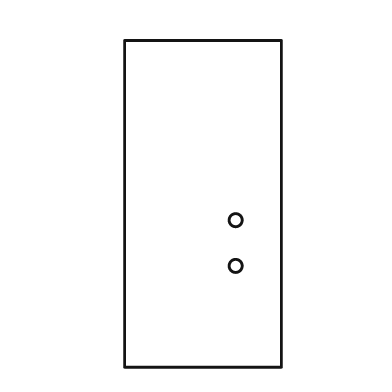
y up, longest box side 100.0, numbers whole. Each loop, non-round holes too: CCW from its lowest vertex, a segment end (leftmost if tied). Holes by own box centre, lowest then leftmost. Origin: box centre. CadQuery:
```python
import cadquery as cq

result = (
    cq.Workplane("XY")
    .moveTo(-24.0, -50.0)
    .lineTo(24.0, -50.0)
    .lineTo(24.0, 50.0)
    .lineTo(-24.0, 50.0)
    .close()
    .moveTo(10.0, -19.0)
    .circle(2.0)
    .moveTo(10.0, -5.0)
    .circle(2.0)
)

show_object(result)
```